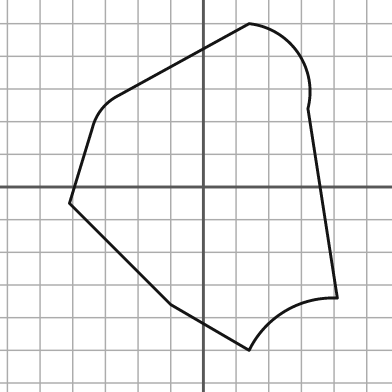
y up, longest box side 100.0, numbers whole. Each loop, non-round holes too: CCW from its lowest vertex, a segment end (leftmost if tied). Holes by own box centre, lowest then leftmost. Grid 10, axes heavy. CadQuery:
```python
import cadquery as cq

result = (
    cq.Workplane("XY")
    .moveTo(14.0, -50.0)
    .threePointArc((25.0, -38.0), (41.0, -34.0))
    .lineTo(32.0, 24.0)
    .threePointArc((29.0, 41.0), (14.0, 50.0))
    .lineTo(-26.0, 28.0)
    .threePointArc((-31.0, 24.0), (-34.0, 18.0))
    .lineTo(-41.0, -5.0)
    .lineTo(-10.0, -36.0)
    .close()
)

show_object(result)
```